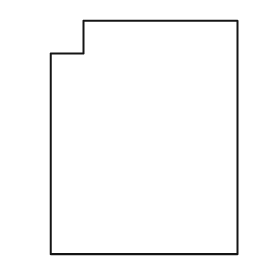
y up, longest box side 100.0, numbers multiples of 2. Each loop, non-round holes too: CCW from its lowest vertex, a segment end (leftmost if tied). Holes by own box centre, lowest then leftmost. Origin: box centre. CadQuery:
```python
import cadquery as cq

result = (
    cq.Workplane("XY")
    .moveTo(-40.0, -50.0)
    .lineTo(40.0, -50.0)
    .lineTo(40.0, 50.0)
    .lineTo(-26.0, 50.0)
    .lineTo(-26.0, 36.0)
    .lineTo(-40.0, 36.0)
    .close()
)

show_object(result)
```